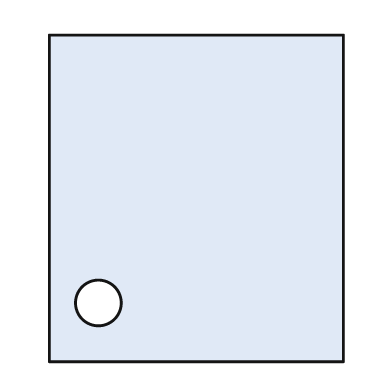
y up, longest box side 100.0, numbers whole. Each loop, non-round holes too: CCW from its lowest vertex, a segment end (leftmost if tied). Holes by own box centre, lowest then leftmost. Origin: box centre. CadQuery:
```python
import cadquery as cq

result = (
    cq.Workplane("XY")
    .moveTo(-45.0, -50.0)
    .lineTo(45.0, -50.0)
    .lineTo(45.0, 50.0)
    .lineTo(-45.0, 50.0)
    .close()
    .moveTo(-30.0, -32.0)
    .circle(7.0)
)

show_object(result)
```